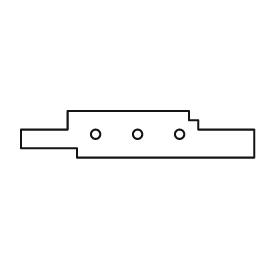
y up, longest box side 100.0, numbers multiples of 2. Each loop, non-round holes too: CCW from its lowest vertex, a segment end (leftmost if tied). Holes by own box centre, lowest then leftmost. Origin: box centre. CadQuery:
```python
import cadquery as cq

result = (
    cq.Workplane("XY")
    .moveTo(-26.0, -10.0)
    .lineTo(50.0, -10.0)
    .lineTo(50.0, 2.0)
    .lineTo(26.0, 2.0)
    .lineTo(26.0, 6.0)
    .lineTo(22.0, 6.0)
    .lineTo(22.0, 10.0)
    .lineTo(-30.0, 10.0)
    .lineTo(-30.0, 2.0)
    .lineTo(-50.0, 2.0)
    .lineTo(-50.0, -6.0)
    .lineTo(-26.0, -6.0)
    .close()
    .moveTo(-18.0, 0.0)
    .circle(2.0)
    .moveTo(0.0, 0.0)
    .circle(2.0)
    .moveTo(18.0, 0.0)
    .circle(2.0)
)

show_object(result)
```